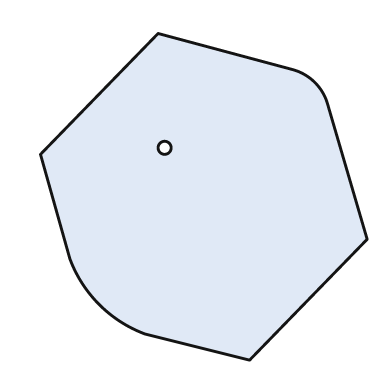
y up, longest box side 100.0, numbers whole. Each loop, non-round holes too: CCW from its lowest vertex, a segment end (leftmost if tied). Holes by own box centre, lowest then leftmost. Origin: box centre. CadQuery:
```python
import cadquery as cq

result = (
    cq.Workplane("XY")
    .moveTo(14.0, -50.0)
    .lineTo(50.0, -13.0)
    .lineTo(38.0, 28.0)
    .threePointArc((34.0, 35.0), (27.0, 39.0))
    .lineTo(-14.0, 50.0)
    .lineTo(-50.0, 13.0)
    .lineTo(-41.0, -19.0)
    .threePointArc((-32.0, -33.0), (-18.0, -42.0))
    .close()
    .moveTo(-12.0, 15.0)
    .circle(2.0)
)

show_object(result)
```